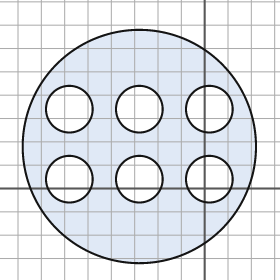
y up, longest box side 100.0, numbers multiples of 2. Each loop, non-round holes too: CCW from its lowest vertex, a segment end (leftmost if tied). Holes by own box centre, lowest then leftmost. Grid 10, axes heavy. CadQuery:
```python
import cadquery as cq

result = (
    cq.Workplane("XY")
    .moveTo(-28.0, 18.0)
    .circle(50.0)
    .moveTo(-58.0, 4.0)
    .circle(10.0)
    .moveTo(-28.0, 4.0)
    .circle(10.0)
    .moveTo(2.0, 4.0)
    .circle(10.0)
    .moveTo(-58.0, 34.0)
    .circle(10.0)
    .moveTo(-28.0, 34.0)
    .circle(10.0)
    .moveTo(2.0, 34.0)
    .circle(10.0)
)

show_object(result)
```